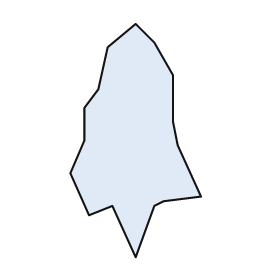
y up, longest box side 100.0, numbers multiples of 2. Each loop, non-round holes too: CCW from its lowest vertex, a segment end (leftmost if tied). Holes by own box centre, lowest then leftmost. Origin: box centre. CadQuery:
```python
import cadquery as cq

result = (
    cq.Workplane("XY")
    .moveTo(0.0, -50.0)
    .lineTo(8.0, -28.0)
    .lineTo(12.0, -26.0)
    .lineTo(28.0, -24.0)
    .lineTo(18.0, -2.0)
    .lineTo(16.0, 8.0)
    .lineTo(16.0, 28.0)
    .lineTo(8.0, 42.0)
    .lineTo(0.0, 50.0)
    .lineTo(-12.0, 40.0)
    .lineTo(-16.0, 22.0)
    .lineTo(-22.0, 14.0)
    .lineTo(-22.0, 0.0)
    .lineTo(-28.0, -14.0)
    .lineTo(-20.0, -32.0)
    .lineTo(-10.0, -28.0)
    .close()
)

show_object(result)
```